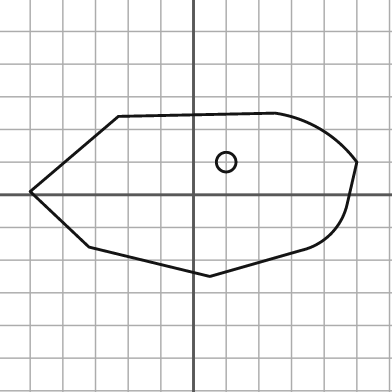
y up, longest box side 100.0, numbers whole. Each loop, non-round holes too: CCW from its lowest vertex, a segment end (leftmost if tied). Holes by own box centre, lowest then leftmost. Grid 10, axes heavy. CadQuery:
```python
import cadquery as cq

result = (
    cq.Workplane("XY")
    .moveTo(5.0, -25.0)
    .lineTo(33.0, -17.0)
    .threePointArc((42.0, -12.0), (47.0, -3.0))
    .lineTo(50.0, 10.0)
    .threePointArc((39.0, 20.0), (25.0, 25.0))
    .lineTo(-23.0, 24.0)
    .lineTo(-50.0, 1.0)
    .lineTo(-32.0, -16.0)
    .close()
    .moveTo(10.0, 10.0)
    .circle(3.0)
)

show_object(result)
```